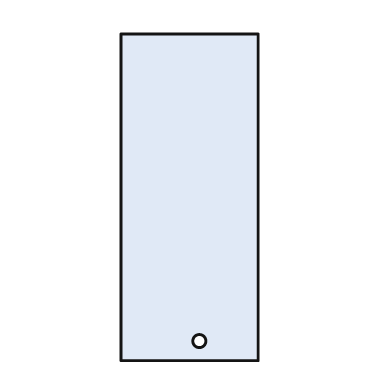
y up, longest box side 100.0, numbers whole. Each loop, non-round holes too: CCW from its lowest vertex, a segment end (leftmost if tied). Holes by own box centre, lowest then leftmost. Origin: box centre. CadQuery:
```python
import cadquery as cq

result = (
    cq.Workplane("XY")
    .moveTo(-21.0, -50.0)
    .lineTo(21.0, -50.0)
    .lineTo(21.0, 50.0)
    .lineTo(-21.0, 50.0)
    .close()
    .moveTo(3.0, -44.0)
    .circle(2.0)
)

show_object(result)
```